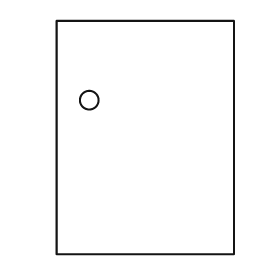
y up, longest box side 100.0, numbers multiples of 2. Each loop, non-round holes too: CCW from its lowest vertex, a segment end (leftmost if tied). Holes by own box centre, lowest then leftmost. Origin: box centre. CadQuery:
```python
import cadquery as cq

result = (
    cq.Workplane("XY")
    .moveTo(-38.0, -50.0)
    .lineTo(38.0, -50.0)
    .lineTo(38.0, 50.0)
    .lineTo(-38.0, 50.0)
    .close()
    .moveTo(-24.0, 16.0)
    .circle(4.0)
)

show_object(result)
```